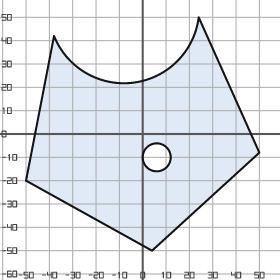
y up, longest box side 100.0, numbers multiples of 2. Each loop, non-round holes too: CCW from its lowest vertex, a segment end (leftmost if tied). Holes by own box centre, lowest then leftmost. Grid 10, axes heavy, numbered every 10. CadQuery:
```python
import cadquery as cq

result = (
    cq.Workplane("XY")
    .moveTo(4.0, -50.0)
    .lineTo(50.0, -8.0)
    .lineTo(24.0, 50.0)
    .threePointArc((-4.0, 22.0), (-38.0, 42.0))
    .lineTo(-50.0, -20.0)
    .close()
    .moveTo(6.0, -10.0)
    .circle(6.0)
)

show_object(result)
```